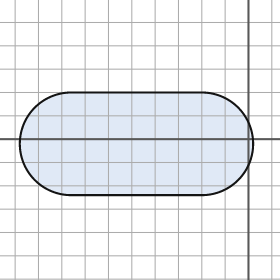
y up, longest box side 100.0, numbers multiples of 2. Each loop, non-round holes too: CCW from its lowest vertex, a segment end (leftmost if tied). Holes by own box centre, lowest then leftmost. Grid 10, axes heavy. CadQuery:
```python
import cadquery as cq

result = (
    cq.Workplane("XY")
    .moveTo(-76.0, -24.0)
    .lineTo(-20.0, -24.0)
    .threePointArc((2.0, -2.0), (-20.0, 20.0))
    .lineTo(-76.0, 20.0)
    .threePointArc((-98.0, -2.0), (-76.0, -24.0))
    .close()
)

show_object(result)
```